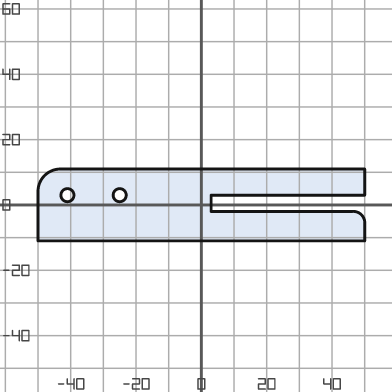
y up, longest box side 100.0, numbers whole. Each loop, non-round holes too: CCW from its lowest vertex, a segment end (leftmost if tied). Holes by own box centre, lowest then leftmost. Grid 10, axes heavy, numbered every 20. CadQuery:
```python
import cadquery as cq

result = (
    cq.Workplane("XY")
    .moveTo(-50.0, -11.0)
    .lineTo(50.0, -11.0)
    .lineTo(50.0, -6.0)
    .threePointArc((49.0, -3.0), (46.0, -2.0))
    .lineTo(3.0, -2.0)
    .lineTo(3.0, 3.0)
    .lineTo(50.0, 3.0)
    .lineTo(50.0, 11.0)
    .lineTo(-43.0, 11.0)
    .threePointArc((-48.0, 9.0), (-50.0, 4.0))
    .close()
    .moveTo(-41.0, 3.0)
    .circle(2.0)
    .moveTo(-25.0, 3.0)
    .circle(2.0)
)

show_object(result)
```